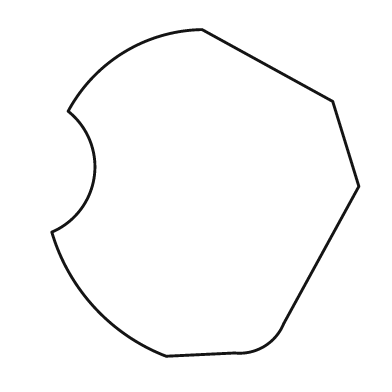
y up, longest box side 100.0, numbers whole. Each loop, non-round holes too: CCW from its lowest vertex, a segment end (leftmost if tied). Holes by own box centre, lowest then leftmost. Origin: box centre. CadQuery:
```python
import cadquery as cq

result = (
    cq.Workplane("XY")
    .moveTo(-12.0, -50.0)
    .lineTo(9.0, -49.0)
    .threePointArc((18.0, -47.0), (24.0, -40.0))
    .lineTo(47.0, 2.0)
    .lineTo(39.0, 28.0)
    .lineTo(-1.0, 50.0)
    .threePointArc((-25.0, 43.0), (-42.0, 25.0))
    .threePointArc((-34.0, 5.0), (-47.0, -12.0))
    .threePointArc((-34.0, -35.0), (-12.0, -50.0))
    .close()
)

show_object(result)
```